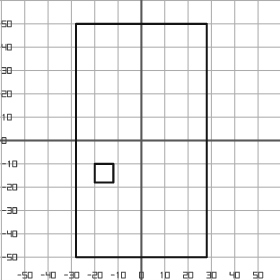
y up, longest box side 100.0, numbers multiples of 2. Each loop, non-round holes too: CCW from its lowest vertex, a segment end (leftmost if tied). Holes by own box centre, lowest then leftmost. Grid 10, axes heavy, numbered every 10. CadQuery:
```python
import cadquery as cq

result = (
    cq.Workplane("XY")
    .moveTo(-28.0, -50.0)
    .lineTo(28.0, -50.0)
    .lineTo(28.0, 50.0)
    .lineTo(-28.0, 50.0)
    .close()
    .moveTo(-20.0, -18.0)
    .lineTo(-12.0, -18.0)
    .lineTo(-12.0, -10.0)
    .lineTo(-20.0, -10.0)
    .close()
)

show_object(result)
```